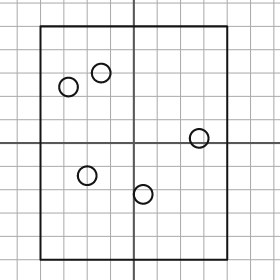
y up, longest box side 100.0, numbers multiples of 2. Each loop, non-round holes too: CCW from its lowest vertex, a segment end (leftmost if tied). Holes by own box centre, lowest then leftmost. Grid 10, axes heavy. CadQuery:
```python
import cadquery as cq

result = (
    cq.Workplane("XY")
    .moveTo(-40.0, -50.0)
    .lineTo(40.0, -50.0)
    .lineTo(40.0, 50.0)
    .lineTo(-40.0, 50.0)
    .close()
    .moveTo(4.0, -22.0)
    .circle(4.0)
    .moveTo(-20.0, -14.0)
    .circle(4.0)
    .moveTo(28.0, 2.0)
    .circle(4.0)
    .moveTo(-28.0, 24.0)
    .circle(4.0)
    .moveTo(-14.0, 30.0)
    .circle(4.0)
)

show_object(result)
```